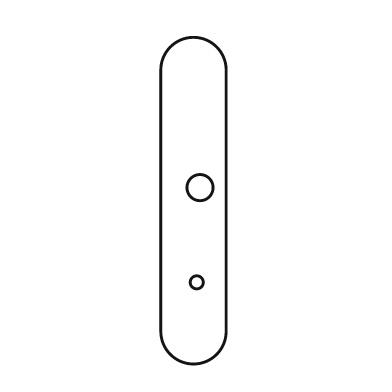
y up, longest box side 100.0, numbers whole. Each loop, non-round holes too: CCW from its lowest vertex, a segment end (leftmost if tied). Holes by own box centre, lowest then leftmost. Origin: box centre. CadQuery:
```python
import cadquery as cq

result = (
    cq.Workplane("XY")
    .moveTo(-10.0, -40.0)
    .threePointArc((0.0, -50.0), (10.0, -40.0))
    .lineTo(10.0, 40.0)
    .threePointArc((0.0, 50.0), (-10.0, 40.0))
    .close()
    .moveTo(1.0, -25.0)
    .circle(2.0)
    .moveTo(2.0, 4.0)
    .circle(4.0)
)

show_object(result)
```